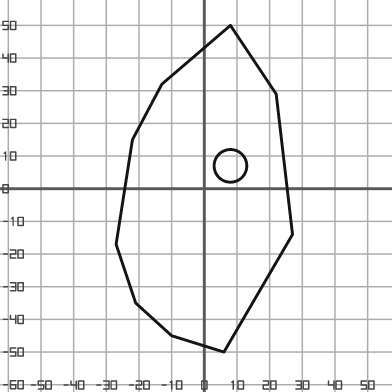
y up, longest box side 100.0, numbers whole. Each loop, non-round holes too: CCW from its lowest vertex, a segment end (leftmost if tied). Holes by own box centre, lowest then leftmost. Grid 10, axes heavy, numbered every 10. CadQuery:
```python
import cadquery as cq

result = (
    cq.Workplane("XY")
    .moveTo(6.0, -50.0)
    .lineTo(27.0, -14.0)
    .lineTo(22.0, 29.0)
    .lineTo(8.0, 50.0)
    .lineTo(-13.0, 32.0)
    .lineTo(-22.0, 15.0)
    .lineTo(-27.0, -17.0)
    .lineTo(-21.0, -35.0)
    .lineTo(-10.0, -45.0)
    .close()
    .moveTo(8.0, 7.0)
    .circle(5.0)
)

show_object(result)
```